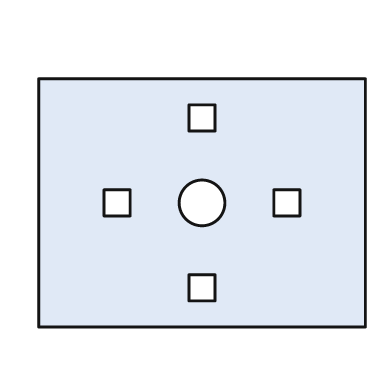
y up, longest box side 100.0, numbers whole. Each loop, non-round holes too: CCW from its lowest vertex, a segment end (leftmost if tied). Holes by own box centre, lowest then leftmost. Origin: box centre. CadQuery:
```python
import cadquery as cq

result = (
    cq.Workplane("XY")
    .moveTo(-50.0, -38.0)
    .lineTo(50.0, -38.0)
    .lineTo(50.0, 38.0)
    .lineTo(-50.0, 38.0)
    .close()
    .moveTo(-4.0, -30.0)
    .lineTo(4.0, -30.0)
    .lineTo(4.0, -22.0)
    .lineTo(-4.0, -22.0)
    .close()
    .moveTo(-30.0, -4.0)
    .lineTo(-22.0, -4.0)
    .lineTo(-22.0, 4.0)
    .lineTo(-30.0, 4.0)
    .close()
    .moveTo(0.0, 0.0)
    .circle(7.0)
    .moveTo(22.0, -4.0)
    .lineTo(30.0, -4.0)
    .lineTo(30.0, 4.0)
    .lineTo(22.0, 4.0)
    .close()
    .moveTo(-4.0, 22.0)
    .lineTo(4.0, 22.0)
    .lineTo(4.0, 30.0)
    .lineTo(-4.0, 30.0)
    .close()
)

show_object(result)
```